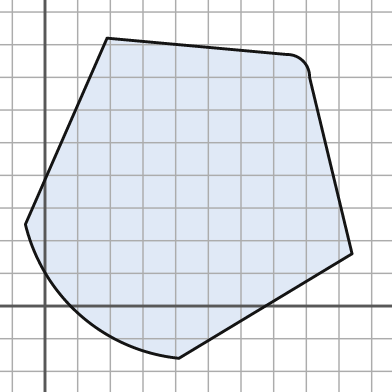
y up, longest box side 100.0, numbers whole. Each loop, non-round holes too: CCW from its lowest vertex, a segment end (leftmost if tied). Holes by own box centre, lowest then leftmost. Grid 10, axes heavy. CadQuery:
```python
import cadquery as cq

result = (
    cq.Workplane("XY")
    .moveTo(41.0, -16.0)
    .lineTo(94.0, 16.0)
    .lineTo(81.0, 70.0)
    .threePointArc((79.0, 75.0), (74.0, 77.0))
    .lineTo(19.0, 82.0)
    .lineTo(-6.0, 25.0)
    .threePointArc((11.0, -3.0), (41.0, -16.0))
    .close()
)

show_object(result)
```